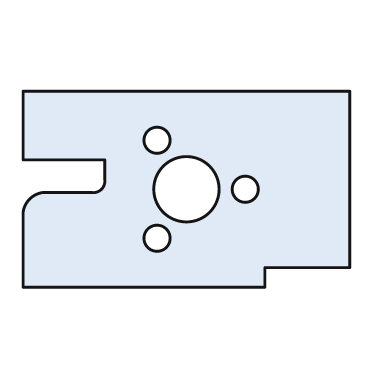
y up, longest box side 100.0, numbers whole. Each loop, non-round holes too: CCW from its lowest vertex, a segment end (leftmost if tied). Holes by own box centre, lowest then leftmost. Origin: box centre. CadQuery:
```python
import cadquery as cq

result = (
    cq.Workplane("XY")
    .moveTo(-50.0, -30.0)
    .lineTo(24.0, -30.0)
    .lineTo(24.0, -24.0)
    .lineTo(50.0, -24.0)
    .lineTo(50.0, 30.0)
    .lineTo(-50.0, 30.0)
    .lineTo(-50.0, 9.0)
    .lineTo(-25.0, 9.0)
    .lineTo(-25.0, 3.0)
    .threePointArc((-26.0, 0.0), (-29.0, -1.0))
    .lineTo(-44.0, -1.0)
    .threePointArc((-48.0, -3.0), (-50.0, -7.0))
    .close()
    .moveTo(-9.0, -15.0)
    .circle(4.0)
    .moveTo(0.0, 0.0)
    .circle(10.0)
    .moveTo(18.0, 0.0)
    .circle(4.0)
    .moveTo(-9.0, 15.0)
    .circle(4.0)
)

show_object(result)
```